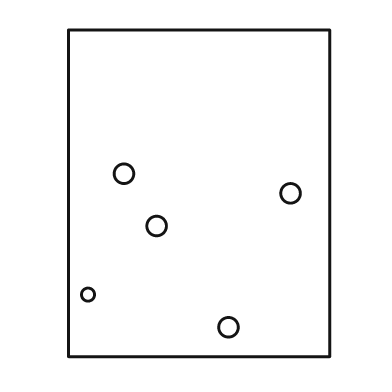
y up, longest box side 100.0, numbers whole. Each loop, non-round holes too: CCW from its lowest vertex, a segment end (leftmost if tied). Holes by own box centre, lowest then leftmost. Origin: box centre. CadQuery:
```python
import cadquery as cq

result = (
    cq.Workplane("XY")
    .moveTo(-40.0, -50.0)
    .lineTo(40.0, -50.0)
    .lineTo(40.0, 50.0)
    .lineTo(-40.0, 50.0)
    .close()
    .moveTo(9.0, -41.0)
    .circle(3.0)
    .moveTo(-34.0, -31.0)
    .circle(2.0)
    .moveTo(-13.0, -10.0)
    .circle(3.0)
    .moveTo(28.0, 0.0)
    .circle(3.0)
    .moveTo(-23.0, 6.0)
    .circle(3.0)
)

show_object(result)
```